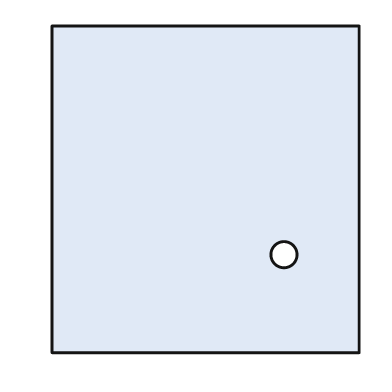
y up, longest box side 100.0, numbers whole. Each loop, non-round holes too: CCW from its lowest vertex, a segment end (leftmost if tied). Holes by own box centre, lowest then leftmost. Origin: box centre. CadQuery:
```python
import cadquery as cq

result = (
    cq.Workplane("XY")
    .moveTo(-47.0, -50.0)
    .lineTo(47.0, -50.0)
    .lineTo(47.0, 50.0)
    .lineTo(-47.0, 50.0)
    .close()
    .moveTo(24.0, -20.0)
    .circle(4.0)
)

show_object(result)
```